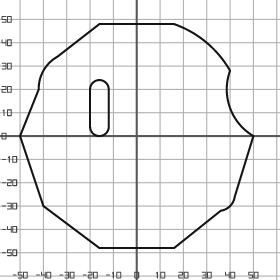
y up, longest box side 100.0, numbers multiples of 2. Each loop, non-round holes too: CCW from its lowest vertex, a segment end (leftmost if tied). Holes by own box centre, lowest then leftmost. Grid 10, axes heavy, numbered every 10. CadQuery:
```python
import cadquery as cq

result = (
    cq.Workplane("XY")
    .moveTo(-16.0, -48.0)
    .lineTo(16.0, -48.0)
    .lineTo(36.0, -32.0)
    .threePointArc((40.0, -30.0), (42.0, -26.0))
    .lineTo(50.0, 0.0)
    .threePointArc((40.0, 12.0), (40.0, 28.0))
    .threePointArc((30.0, 40.0), (16.0, 48.0))
    .lineTo(-16.0, 48.0)
    .lineTo(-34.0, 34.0)
    .threePointArc((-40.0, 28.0), (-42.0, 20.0))
    .lineTo(-50.0, 0.0)
    .lineTo(-40.0, -30.0)
    .close()
    .moveTo(-20.0, 4.0)
    .threePointArc((-16.0, 0.0), (-12.0, 4.0))
    .lineTo(-12.0, 20.0)
    .threePointArc((-16.0, 24.0), (-20.0, 20.0))
    .close()
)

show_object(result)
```